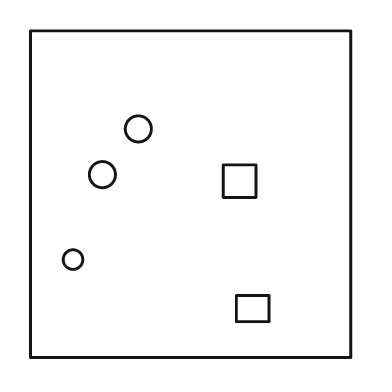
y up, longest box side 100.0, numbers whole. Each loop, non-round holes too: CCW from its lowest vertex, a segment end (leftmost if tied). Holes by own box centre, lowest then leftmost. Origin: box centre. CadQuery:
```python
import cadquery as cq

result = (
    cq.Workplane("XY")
    .moveTo(-49.0, -50.0)
    .lineTo(49.0, -50.0)
    .lineTo(49.0, 50.0)
    .lineTo(-49.0, 50.0)
    .close()
    .moveTo(14.0, -39.0)
    .lineTo(24.0, -39.0)
    .lineTo(24.0, -31.0)
    .lineTo(14.0, -31.0)
    .close()
    .moveTo(-36.0, -20.0)
    .circle(3.0)
    .moveTo(10.0, -1.0)
    .lineTo(20.0, -1.0)
    .lineTo(20.0, 9.0)
    .lineTo(10.0, 9.0)
    .close()
    .moveTo(-27.0, 6.0)
    .circle(4.0)
    .moveTo(-16.0, 20.0)
    .circle(4.0)
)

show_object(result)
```